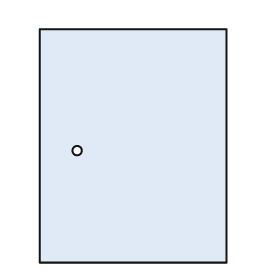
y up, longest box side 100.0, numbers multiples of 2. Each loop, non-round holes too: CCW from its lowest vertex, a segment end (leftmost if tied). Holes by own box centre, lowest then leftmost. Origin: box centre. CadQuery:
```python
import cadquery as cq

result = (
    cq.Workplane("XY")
    .moveTo(-40.0, -50.0)
    .lineTo(40.0, -50.0)
    .lineTo(40.0, 50.0)
    .lineTo(-40.0, 50.0)
    .close()
    .moveTo(-24.0, -2.0)
    .circle(2.0)
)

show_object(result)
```